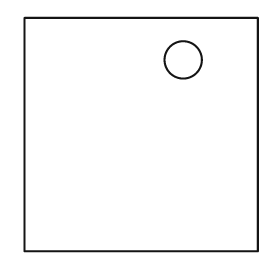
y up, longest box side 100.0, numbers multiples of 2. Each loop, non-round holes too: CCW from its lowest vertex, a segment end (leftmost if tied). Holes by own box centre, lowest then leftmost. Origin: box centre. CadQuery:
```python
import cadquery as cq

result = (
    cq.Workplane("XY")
    .moveTo(-50.0, -50.0)
    .lineTo(50.0, -50.0)
    .lineTo(50.0, 50.0)
    .lineTo(-50.0, 50.0)
    .close()
    .moveTo(18.0, 32.0)
    .circle(8.0)
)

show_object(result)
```